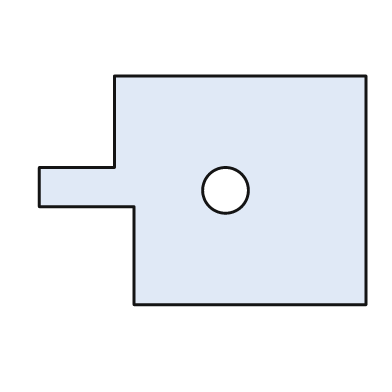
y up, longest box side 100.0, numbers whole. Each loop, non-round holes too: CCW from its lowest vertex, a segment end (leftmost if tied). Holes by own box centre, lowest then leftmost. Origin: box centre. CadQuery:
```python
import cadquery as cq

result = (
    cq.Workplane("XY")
    .moveTo(-21.0, -35.0)
    .lineTo(50.0, -35.0)
    .lineTo(50.0, 35.0)
    .lineTo(-27.0, 35.0)
    .lineTo(-27.0, 7.0)
    .lineTo(-50.0, 7.0)
    .lineTo(-50.0, -5.0)
    .lineTo(-21.0, -5.0)
    .close()
    .moveTo(7.0, 0.0)
    .circle(7.0)
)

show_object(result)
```